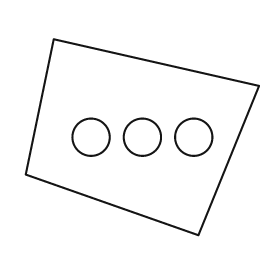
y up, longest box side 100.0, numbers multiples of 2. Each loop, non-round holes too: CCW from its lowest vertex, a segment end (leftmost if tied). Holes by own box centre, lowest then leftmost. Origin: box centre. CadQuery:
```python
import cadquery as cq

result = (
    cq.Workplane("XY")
    .moveTo(24.0, -42.0)
    .lineTo(50.0, 22.0)
    .lineTo(-38.0, 42.0)
    .lineTo(-50.0, -16.0)
    .close()
    .moveTo(-22.0, 0.0)
    .circle(8.0)
    .moveTo(0.0, 0.0)
    .circle(8.0)
    .moveTo(22.0, 0.0)
    .circle(8.0)
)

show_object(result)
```